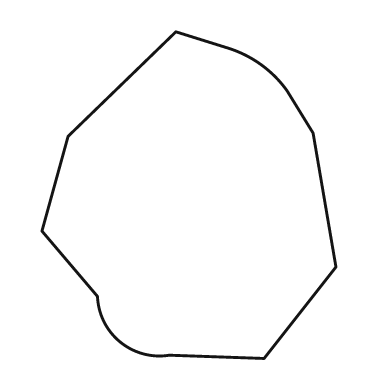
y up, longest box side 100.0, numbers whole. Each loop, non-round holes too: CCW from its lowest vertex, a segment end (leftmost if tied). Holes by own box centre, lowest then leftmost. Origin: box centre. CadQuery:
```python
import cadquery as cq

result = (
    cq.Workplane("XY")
    .moveTo(23.0, -50.0)
    .lineTo(45.0, -22.0)
    .lineTo(38.0, 19.0)
    .lineTo(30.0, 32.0)
    .threePointArc((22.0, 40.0), (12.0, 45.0))
    .lineTo(-4.0, 50.0)
    .lineTo(-37.0, 18.0)
    .lineTo(-45.0, -11.0)
    .lineTo(-28.0, -31.0)
    .threePointArc((-21.0, -45.0), (-6.0, -49.0))
    .close()
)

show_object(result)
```